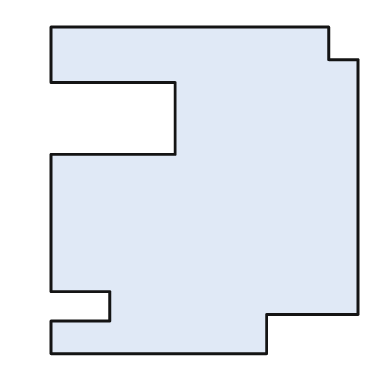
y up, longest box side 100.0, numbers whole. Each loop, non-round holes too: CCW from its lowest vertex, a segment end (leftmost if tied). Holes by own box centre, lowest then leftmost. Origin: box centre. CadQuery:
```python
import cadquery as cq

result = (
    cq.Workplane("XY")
    .moveTo(-47.0, -50.0)
    .lineTo(19.0, -50.0)
    .lineTo(19.0, -38.0)
    .lineTo(47.0, -38.0)
    .lineTo(47.0, 40.0)
    .lineTo(38.0, 40.0)
    .lineTo(38.0, 50.0)
    .lineTo(-47.0, 50.0)
    .lineTo(-47.0, 33.0)
    .lineTo(-9.0, 33.0)
    .lineTo(-9.0, 11.0)
    .lineTo(-47.0, 11.0)
    .lineTo(-47.0, -31.0)
    .lineTo(-29.0, -31.0)
    .lineTo(-29.0, -40.0)
    .lineTo(-47.0, -40.0)
    .close()
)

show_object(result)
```